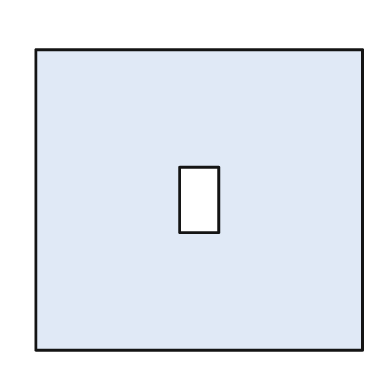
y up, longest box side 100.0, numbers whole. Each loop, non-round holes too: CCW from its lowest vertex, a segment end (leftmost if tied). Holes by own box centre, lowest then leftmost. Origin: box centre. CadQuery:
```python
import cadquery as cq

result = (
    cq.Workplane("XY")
    .moveTo(-50.0, -46.0)
    .lineTo(50.0, -46.0)
    .lineTo(50.0, 46.0)
    .lineTo(-50.0, 46.0)
    .close()
    .moveTo(-6.0, -10.0)
    .lineTo(6.0, -10.0)
    .lineTo(6.0, 10.0)
    .lineTo(-6.0, 10.0)
    .close()
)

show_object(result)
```